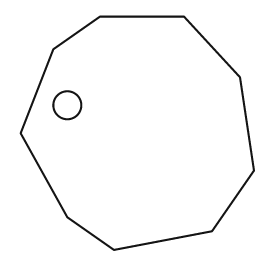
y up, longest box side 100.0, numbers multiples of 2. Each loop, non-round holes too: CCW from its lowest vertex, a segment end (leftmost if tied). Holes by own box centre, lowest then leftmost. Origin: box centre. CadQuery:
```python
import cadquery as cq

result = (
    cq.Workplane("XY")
    .moveTo(-10.0, -50.0)
    .lineTo(32.0, -42.0)
    .lineTo(50.0, -16.0)
    .lineTo(44.0, 24.0)
    .lineTo(20.0, 50.0)
    .lineTo(-16.0, 50.0)
    .lineTo(-36.0, 36.0)
    .lineTo(-50.0, 0.0)
    .lineTo(-30.0, -36.0)
    .close()
    .moveTo(-30.0, 12.0)
    .circle(6.0)
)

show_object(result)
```